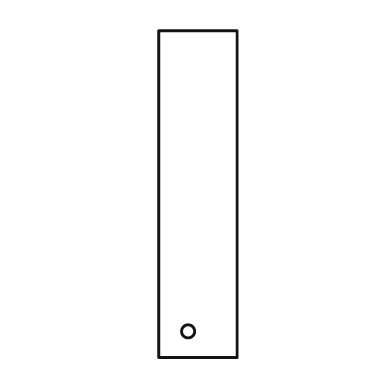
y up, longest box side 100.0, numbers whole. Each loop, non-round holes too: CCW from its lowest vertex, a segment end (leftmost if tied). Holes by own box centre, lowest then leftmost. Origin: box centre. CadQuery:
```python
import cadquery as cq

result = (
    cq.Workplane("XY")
    .moveTo(-12.0, -50.0)
    .lineTo(12.0, -50.0)
    .lineTo(12.0, 50.0)
    .lineTo(-12.0, 50.0)
    .close()
    .moveTo(-3.0, -42.0)
    .circle(2.0)
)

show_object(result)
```